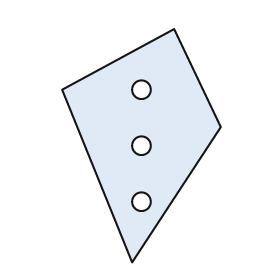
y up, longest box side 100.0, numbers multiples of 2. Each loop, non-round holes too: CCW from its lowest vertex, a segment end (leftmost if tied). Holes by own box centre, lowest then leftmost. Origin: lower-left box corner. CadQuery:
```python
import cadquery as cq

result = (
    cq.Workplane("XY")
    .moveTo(30.0, 0.0)
    .lineTo(68.0, 58.0)
    .lineTo(48.0, 100.0)
    .lineTo(0.0, 74.0)
    .close()
    .moveTo(34.0, 26.0)
    .circle(4.0)
    .moveTo(34.0, 50.0)
    .circle(4.0)
    .moveTo(34.0, 74.0)
    .circle(4.0)
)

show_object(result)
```